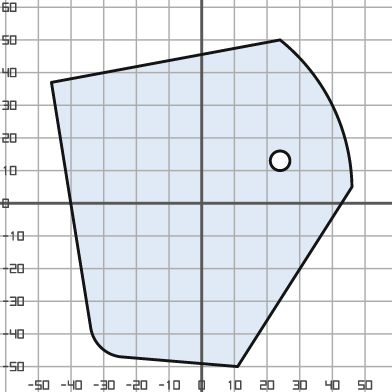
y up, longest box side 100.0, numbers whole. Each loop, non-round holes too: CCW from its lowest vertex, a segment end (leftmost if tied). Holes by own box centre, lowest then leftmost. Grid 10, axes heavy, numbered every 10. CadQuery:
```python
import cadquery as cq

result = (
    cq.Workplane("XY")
    .moveTo(11.0, -50.0)
    .lineTo(46.0, 5.0)
    .threePointArc((40.0, 30.0), (24.0, 50.0))
    .lineTo(-46.0, 37.0)
    .lineTo(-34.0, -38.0)
    .threePointArc((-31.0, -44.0), (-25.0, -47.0))
    .close()
    .moveTo(24.0, 13.0)
    .circle(3.0)
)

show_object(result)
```